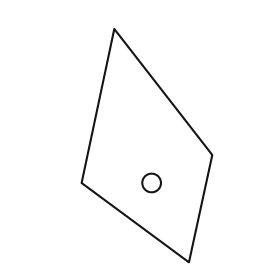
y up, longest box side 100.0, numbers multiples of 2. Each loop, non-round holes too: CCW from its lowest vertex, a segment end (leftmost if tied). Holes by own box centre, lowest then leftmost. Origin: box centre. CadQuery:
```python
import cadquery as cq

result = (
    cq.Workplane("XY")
    .moveTo(18.0, -50.0)
    .lineTo(28.0, -4.0)
    .lineTo(-14.0, 50.0)
    .lineTo(-28.0, -16.0)
    .close()
    .moveTo(2.0, -16.0)
    .circle(4.0)
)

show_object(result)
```